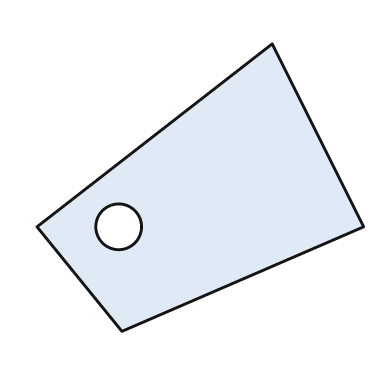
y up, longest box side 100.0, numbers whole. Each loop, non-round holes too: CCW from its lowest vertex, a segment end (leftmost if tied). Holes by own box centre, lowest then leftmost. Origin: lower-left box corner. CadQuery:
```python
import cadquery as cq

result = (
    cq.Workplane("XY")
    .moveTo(26.0, 0.0)
    .lineTo(100.0, 32.0)
    .lineTo(72.0, 88.0)
    .lineTo(0.0, 32.0)
    .close()
    .moveTo(25.0, 32.0)
    .circle(7.0)
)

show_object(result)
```